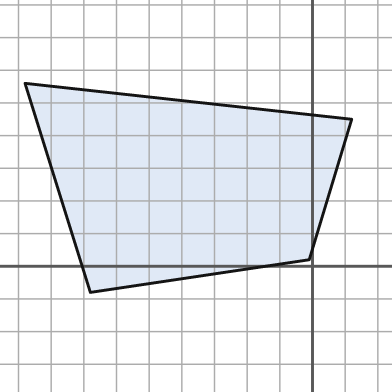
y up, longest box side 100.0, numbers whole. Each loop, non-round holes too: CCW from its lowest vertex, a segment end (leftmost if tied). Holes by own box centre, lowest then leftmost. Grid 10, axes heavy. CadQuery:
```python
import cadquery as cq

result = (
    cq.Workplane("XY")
    .moveTo(-68.0, -8.0)
    .lineTo(-1.0, 2.0)
    .lineTo(12.0, 45.0)
    .lineTo(-88.0, 56.0)
    .close()
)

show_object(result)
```